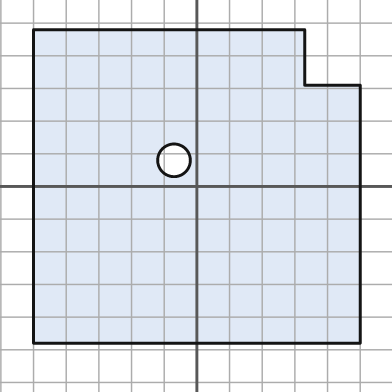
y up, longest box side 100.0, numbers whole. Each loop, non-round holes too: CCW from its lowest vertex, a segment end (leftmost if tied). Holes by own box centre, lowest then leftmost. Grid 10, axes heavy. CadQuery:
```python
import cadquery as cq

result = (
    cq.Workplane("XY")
    .moveTo(-50.0, -48.0)
    .lineTo(50.0, -48.0)
    .lineTo(50.0, 31.0)
    .lineTo(33.0, 31.0)
    .lineTo(33.0, 48.0)
    .lineTo(-50.0, 48.0)
    .close()
    .moveTo(-7.0, 8.0)
    .circle(5.0)
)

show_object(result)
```